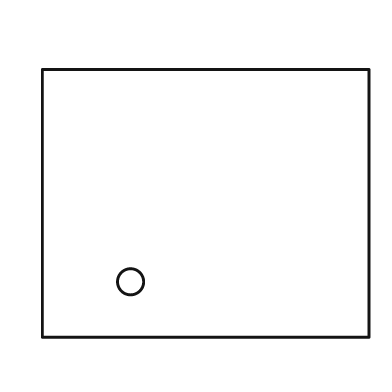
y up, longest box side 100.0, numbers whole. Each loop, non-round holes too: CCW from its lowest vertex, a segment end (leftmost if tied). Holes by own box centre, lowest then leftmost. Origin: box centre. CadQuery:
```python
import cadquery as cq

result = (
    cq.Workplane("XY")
    .moveTo(-50.0, -41.0)
    .lineTo(50.0, -41.0)
    .lineTo(50.0, 41.0)
    .lineTo(-50.0, 41.0)
    .close()
    .moveTo(-23.0, -24.0)
    .circle(4.0)
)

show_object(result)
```